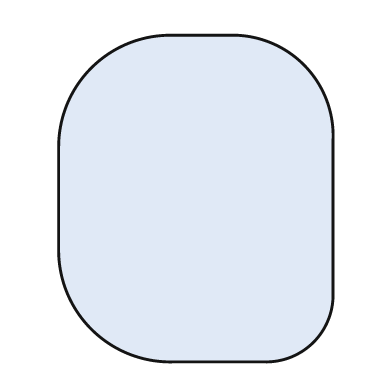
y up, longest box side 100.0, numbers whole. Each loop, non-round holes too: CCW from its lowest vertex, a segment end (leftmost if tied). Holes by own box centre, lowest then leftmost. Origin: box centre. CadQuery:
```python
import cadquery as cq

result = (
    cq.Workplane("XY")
    .moveTo(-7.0, -50.0)
    .lineTo(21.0, -50.0)
    .threePointArc((36.0, -44.0), (42.0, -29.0))
    .lineTo(42.0, 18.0)
    .threePointArc((33.0, 41.0), (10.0, 50.0))
    .lineTo(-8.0, 50.0)
    .threePointArc((-32.0, 40.0), (-42.0, 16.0))
    .lineTo(-42.0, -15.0)
    .threePointArc((-32.0, -40.0), (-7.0, -50.0))
    .close()
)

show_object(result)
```